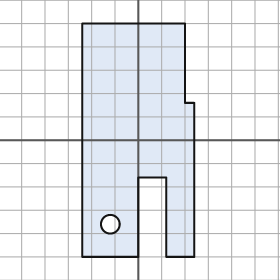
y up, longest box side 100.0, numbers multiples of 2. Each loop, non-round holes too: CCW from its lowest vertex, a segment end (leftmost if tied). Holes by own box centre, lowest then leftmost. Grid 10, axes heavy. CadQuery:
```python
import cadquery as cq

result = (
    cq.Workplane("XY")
    .moveTo(-24.0, -50.0)
    .lineTo(0.0, -50.0)
    .lineTo(0.0, -16.0)
    .lineTo(12.0, -16.0)
    .lineTo(12.0, -50.0)
    .lineTo(24.0, -50.0)
    .lineTo(24.0, 16.0)
    .lineTo(20.0, 16.0)
    .lineTo(20.0, 50.0)
    .lineTo(-24.0, 50.0)
    .close()
    .moveTo(-12.0, -36.0)
    .circle(4.0)
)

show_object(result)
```